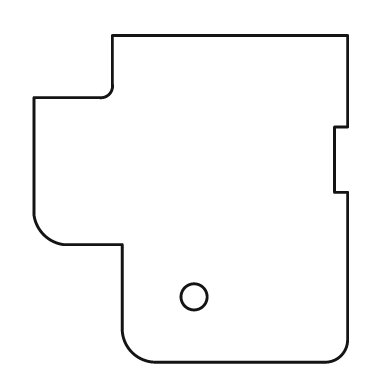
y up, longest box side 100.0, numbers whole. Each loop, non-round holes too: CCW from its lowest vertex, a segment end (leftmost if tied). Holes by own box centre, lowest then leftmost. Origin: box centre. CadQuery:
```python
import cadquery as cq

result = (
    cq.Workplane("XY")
    .moveTo(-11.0, -50.0)
    .lineTo(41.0, -50.0)
    .threePointArc((46.0, -48.0), (48.0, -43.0))
    .lineTo(48.0, 2.0)
    .lineTo(44.0, 2.0)
    .lineTo(44.0, 22.0)
    .lineTo(48.0, 22.0)
    .lineTo(48.0, 50.0)
    .lineTo(-24.0, 50.0)
    .lineTo(-24.0, 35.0)
    .threePointArc((-25.0, 32.0), (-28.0, 31.0))
    .lineTo(-48.0, 31.0)
    .lineTo(-48.0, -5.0)
    .threePointArc((-45.0, -11.0), (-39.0, -14.0))
    .lineTo(-21.0, -14.0)
    .lineTo(-21.0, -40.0)
    .threePointArc((-18.0, -47.0), (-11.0, -50.0))
    .close()
    .moveTo(1.0, -30.0)
    .circle(4.0)
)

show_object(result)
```